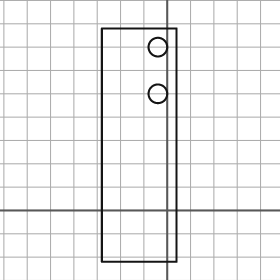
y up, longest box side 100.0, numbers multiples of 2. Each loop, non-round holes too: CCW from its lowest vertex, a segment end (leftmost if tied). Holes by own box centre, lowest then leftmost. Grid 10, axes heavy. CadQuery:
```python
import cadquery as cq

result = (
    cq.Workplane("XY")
    .moveTo(-28.0, -22.0)
    .lineTo(4.0, -22.0)
    .lineTo(4.0, 78.0)
    .lineTo(-28.0, 78.0)
    .close()
    .moveTo(-4.0, 50.0)
    .circle(4.0)
    .moveTo(-4.0, 70.0)
    .circle(4.0)
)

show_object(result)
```